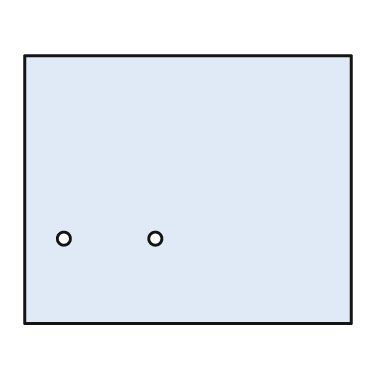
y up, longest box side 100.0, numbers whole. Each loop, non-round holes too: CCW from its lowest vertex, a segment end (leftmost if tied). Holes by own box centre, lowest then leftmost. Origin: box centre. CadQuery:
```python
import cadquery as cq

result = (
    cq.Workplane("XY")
    .moveTo(-50.0, -41.0)
    .lineTo(50.0, -41.0)
    .lineTo(50.0, 41.0)
    .lineTo(-50.0, 41.0)
    .close()
    .moveTo(-38.0, -15.0)
    .circle(2.0)
    .moveTo(-10.0, -15.0)
    .circle(2.0)
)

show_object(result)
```